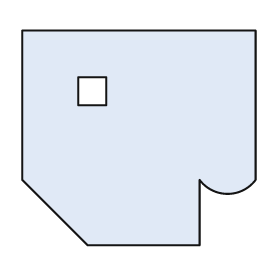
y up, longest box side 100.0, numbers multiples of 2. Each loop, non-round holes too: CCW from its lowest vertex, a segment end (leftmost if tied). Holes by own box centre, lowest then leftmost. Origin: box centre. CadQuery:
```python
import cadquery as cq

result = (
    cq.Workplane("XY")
    .moveTo(-22.0, -46.0)
    .lineTo(26.0, -46.0)
    .lineTo(26.0, -18.0)
    .threePointArc((38.0, -24.0), (50.0, -18.0))
    .lineTo(50.0, 46.0)
    .lineTo(-50.0, 46.0)
    .lineTo(-50.0, -18.0)
    .close()
    .moveTo(-26.0, 14.0)
    .lineTo(-14.0, 14.0)
    .lineTo(-14.0, 26.0)
    .lineTo(-26.0, 26.0)
    .close()
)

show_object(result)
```